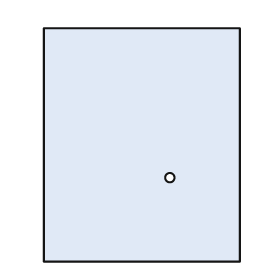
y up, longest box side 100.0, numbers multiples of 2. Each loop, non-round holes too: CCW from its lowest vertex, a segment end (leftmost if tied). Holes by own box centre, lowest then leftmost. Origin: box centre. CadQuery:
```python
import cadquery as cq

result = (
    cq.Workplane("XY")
    .moveTo(-42.0, -50.0)
    .lineTo(42.0, -50.0)
    .lineTo(42.0, 50.0)
    .lineTo(-42.0, 50.0)
    .close()
    .moveTo(12.0, -14.0)
    .circle(2.0)
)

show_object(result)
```